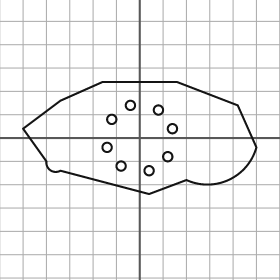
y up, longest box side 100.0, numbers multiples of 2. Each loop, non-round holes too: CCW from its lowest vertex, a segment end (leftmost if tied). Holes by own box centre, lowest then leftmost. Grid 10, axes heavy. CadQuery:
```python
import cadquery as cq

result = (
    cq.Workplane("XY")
    .moveTo(4.0, -24.0)
    .lineTo(20.0, -18.0)
    .threePointArc((38.0, -18.0), (50.0, -4.0))
    .lineTo(42.0, 14.0)
    .lineTo(16.0, 24.0)
    .lineTo(-16.0, 24.0)
    .lineTo(-34.0, 16.0)
    .lineTo(-50.0, 4.0)
    .lineTo(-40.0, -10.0)
    .threePointArc((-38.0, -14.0), (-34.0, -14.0))
    .close()
    .moveTo(4.0, -14.0)
    .circle(2.0)
    .moveTo(-8.0, -12.0)
    .circle(2.0)
    .moveTo(12.0, -8.0)
    .circle(2.0)
    .moveTo(-14.0, -4.0)
    .circle(2.0)
    .moveTo(14.0, 4.0)
    .circle(2.0)
    .moveTo(-12.0, 8.0)
    .circle(2.0)
    .moveTo(8.0, 12.0)
    .circle(2.0)
    .moveTo(-4.0, 14.0)
    .circle(2.0)
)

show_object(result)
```